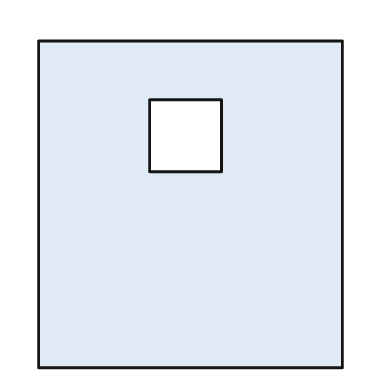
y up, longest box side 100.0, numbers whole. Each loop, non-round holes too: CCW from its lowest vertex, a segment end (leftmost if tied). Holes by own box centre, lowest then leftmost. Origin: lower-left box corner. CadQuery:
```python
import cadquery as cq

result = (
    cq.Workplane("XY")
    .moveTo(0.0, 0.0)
    .lineTo(93.0, 0.0)
    .lineTo(93.0, 100.0)
    .lineTo(0.0, 100.0)
    .close()
    .moveTo(34.0, 60.0)
    .lineTo(56.0, 60.0)
    .lineTo(56.0, 82.0)
    .lineTo(34.0, 82.0)
    .close()
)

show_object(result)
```